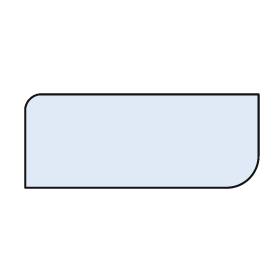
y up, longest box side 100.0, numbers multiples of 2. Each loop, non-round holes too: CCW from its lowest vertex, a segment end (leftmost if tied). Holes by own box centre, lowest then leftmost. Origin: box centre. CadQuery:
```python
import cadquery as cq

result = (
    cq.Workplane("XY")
    .moveTo(-50.0, -20.0)
    .lineTo(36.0, -20.0)
    .threePointArc((46.0, -16.0), (50.0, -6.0))
    .lineTo(50.0, 20.0)
    .lineTo(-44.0, 20.0)
    .threePointArc((-48.0, 18.0), (-50.0, 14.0))
    .close()
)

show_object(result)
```